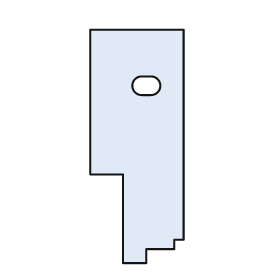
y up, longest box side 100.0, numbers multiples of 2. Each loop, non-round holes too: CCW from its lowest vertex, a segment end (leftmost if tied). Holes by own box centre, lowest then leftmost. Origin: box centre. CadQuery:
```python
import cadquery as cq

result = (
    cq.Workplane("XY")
    .moveTo(-6.0, -50.0)
    .lineTo(4.0, -50.0)
    .lineTo(4.0, -44.0)
    .lineTo(16.0, -44.0)
    .lineTo(16.0, -40.0)
    .lineTo(20.0, -40.0)
    .lineTo(20.0, 50.0)
    .lineTo(-20.0, 50.0)
    .lineTo(-20.0, -12.0)
    .lineTo(-6.0, -12.0)
    .close()
    .moveTo(2.0, 22.0)
    .lineTo(6.0, 22.0)
    .threePointArc((10.0, 26.0), (6.0, 30.0))
    .lineTo(2.0, 30.0)
    .threePointArc((-2.0, 26.0), (2.0, 22.0))
    .close()
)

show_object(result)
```